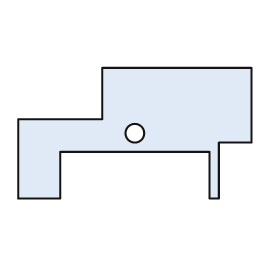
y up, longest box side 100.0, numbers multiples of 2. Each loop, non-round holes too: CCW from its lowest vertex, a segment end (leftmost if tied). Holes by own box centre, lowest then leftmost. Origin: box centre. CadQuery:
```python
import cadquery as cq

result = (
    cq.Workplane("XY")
    .moveTo(-50.0, -28.0)
    .lineTo(-32.0, -28.0)
    .lineTo(-32.0, -8.0)
    .lineTo(32.0, -8.0)
    .lineTo(32.0, -28.0)
    .lineTo(36.0, -28.0)
    .lineTo(36.0, -4.0)
    .lineTo(50.0, -4.0)
    .lineTo(50.0, 28.0)
    .lineTo(-14.0, 28.0)
    .lineTo(-14.0, 6.0)
    .lineTo(-50.0, 6.0)
    .close()
    .moveTo(0.0, 0.0)
    .circle(4.0)
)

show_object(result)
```